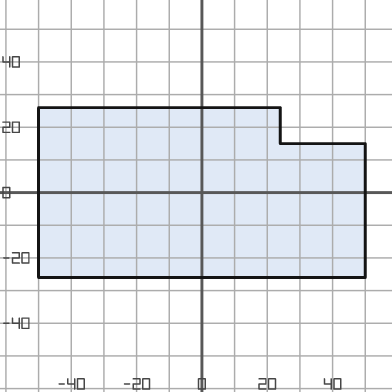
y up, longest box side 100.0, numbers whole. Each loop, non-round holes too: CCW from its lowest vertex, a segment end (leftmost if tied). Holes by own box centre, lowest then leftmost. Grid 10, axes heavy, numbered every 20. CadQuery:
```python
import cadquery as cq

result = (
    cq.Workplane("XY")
    .moveTo(-50.0, -26.0)
    .lineTo(50.0, -26.0)
    .lineTo(50.0, 15.0)
    .lineTo(24.0, 15.0)
    .lineTo(24.0, 26.0)
    .lineTo(-50.0, 26.0)
    .close()
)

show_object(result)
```